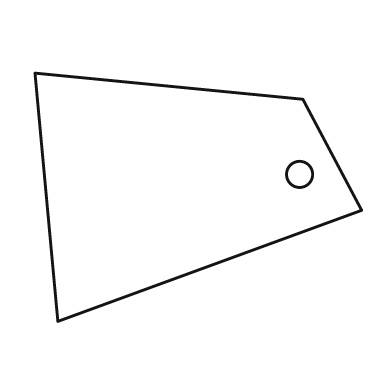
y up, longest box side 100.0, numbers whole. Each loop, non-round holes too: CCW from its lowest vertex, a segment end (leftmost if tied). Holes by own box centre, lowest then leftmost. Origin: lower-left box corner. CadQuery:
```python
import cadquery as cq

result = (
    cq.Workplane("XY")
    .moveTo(7.0, 0.0)
    .lineTo(100.0, 34.0)
    .lineTo(82.0, 68.0)
    .lineTo(0.0, 76.0)
    .close()
    .moveTo(81.0, 45.0)
    .circle(4.0)
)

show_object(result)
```